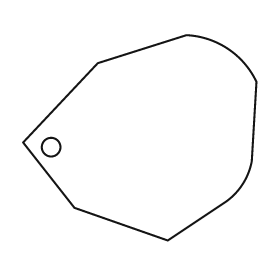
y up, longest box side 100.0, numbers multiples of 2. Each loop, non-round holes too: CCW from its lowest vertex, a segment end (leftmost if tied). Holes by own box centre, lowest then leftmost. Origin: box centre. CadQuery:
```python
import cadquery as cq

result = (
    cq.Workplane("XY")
    .moveTo(12.0, -44.0)
    .lineTo(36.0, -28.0)
    .threePointArc((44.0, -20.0), (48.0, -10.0))
    .lineTo(50.0, 24.0)
    .threePointArc((38.0, 38.0), (20.0, 44.0))
    .lineTo(-18.0, 32.0)
    .lineTo(-50.0, -2.0)
    .lineTo(-28.0, -30.0)
    .close()
    .moveTo(-38.0, -4.0)
    .circle(4.0)
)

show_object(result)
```